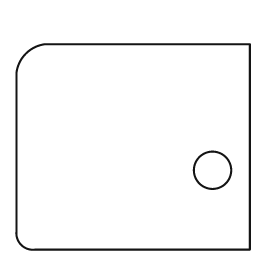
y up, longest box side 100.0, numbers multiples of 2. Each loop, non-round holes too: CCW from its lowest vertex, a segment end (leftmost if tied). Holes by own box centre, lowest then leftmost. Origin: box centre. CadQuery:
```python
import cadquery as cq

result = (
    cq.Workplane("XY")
    .moveTo(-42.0, -44.0)
    .lineTo(50.0, -44.0)
    .lineTo(50.0, 44.0)
    .lineTo(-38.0, 44.0)
    .threePointArc((-46.0, 40.0), (-50.0, 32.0))
    .lineTo(-50.0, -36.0)
    .threePointArc((-48.0, -42.0), (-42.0, -44.0))
    .close()
    .moveTo(34.0, -10.0)
    .circle(8.0)
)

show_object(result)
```